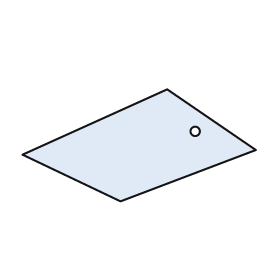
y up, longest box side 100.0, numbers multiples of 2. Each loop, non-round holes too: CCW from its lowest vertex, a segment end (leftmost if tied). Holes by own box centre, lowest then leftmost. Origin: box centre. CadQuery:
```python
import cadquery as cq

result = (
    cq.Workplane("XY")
    .moveTo(-8.0, -24.0)
    .lineTo(50.0, -2.0)
    .lineTo(12.0, 24.0)
    .lineTo(-50.0, -4.0)
    .close()
    .moveTo(24.0, 6.0)
    .circle(2.0)
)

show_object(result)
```